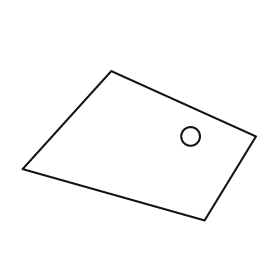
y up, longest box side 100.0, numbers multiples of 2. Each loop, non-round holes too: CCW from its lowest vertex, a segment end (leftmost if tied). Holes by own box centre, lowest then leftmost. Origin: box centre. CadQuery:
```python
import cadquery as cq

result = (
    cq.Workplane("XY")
    .moveTo(28.0, -32.0)
    .lineTo(50.0, 4.0)
    .lineTo(-12.0, 32.0)
    .lineTo(-50.0, -10.0)
    .close()
    .moveTo(22.0, 4.0)
    .circle(4.0)
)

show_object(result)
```